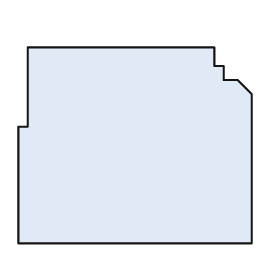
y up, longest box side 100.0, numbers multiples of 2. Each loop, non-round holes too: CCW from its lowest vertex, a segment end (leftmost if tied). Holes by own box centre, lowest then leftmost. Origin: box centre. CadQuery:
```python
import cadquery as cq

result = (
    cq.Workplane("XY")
    .moveTo(-50.0, -42.0)
    .lineTo(50.0, -42.0)
    .lineTo(50.0, 22.0)
    .lineTo(44.0, 28.0)
    .lineTo(38.0, 28.0)
    .lineTo(38.0, 34.0)
    .lineTo(34.0, 34.0)
    .lineTo(34.0, 42.0)
    .lineTo(-46.0, 42.0)
    .lineTo(-46.0, 8.0)
    .lineTo(-50.0, 8.0)
    .close()
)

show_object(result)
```